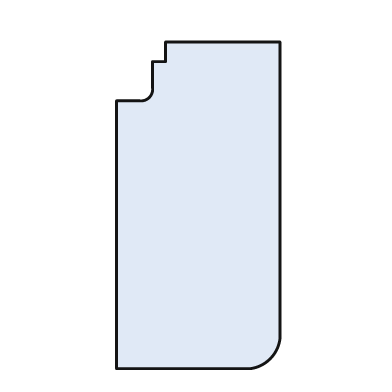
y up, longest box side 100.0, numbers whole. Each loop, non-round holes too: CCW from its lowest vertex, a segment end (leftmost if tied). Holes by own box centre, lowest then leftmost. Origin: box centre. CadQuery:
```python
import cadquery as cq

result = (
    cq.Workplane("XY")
    .moveTo(-25.0, -50.0)
    .lineTo(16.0, -50.0)
    .threePointArc((22.0, -47.0), (25.0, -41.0))
    .lineTo(25.0, 50.0)
    .lineTo(-10.0, 50.0)
    .lineTo(-10.0, 44.0)
    .lineTo(-14.0, 44.0)
    .lineTo(-14.0, 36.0)
    .threePointArc((-15.0, 33.0), (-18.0, 32.0))
    .lineTo(-25.0, 32.0)
    .close()
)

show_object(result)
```